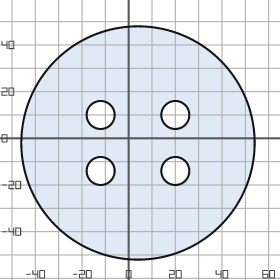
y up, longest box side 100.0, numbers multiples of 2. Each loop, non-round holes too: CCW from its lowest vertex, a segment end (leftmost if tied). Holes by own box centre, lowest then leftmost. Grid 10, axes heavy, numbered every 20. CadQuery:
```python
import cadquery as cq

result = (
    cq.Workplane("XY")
    .moveTo(4.0, -2.0)
    .circle(50.0)
    .moveTo(-12.0, -14.0)
    .circle(6.0)
    .moveTo(20.0, -14.0)
    .circle(6.0)
    .moveTo(-12.0, 10.0)
    .circle(6.0)
    .moveTo(20.0, 10.0)
    .circle(6.0)
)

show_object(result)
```